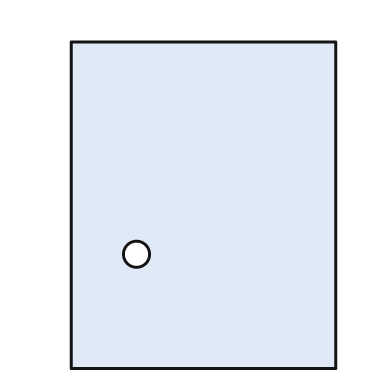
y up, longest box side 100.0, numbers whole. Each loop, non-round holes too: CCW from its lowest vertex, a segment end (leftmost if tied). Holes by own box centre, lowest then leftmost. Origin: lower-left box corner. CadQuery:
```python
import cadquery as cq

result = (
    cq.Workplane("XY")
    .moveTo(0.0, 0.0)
    .lineTo(81.0, 0.0)
    .lineTo(81.0, 100.0)
    .lineTo(0.0, 100.0)
    .close()
    .moveTo(20.0, 35.0)
    .circle(4.0)
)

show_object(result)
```